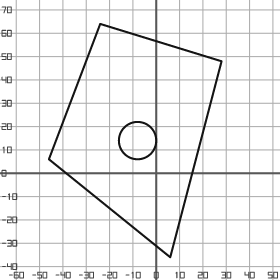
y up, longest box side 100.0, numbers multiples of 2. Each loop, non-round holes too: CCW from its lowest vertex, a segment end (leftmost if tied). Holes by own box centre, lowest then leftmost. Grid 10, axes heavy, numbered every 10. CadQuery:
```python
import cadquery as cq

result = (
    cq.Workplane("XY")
    .moveTo(6.0, -36.0)
    .lineTo(28.0, 48.0)
    .lineTo(-24.0, 64.0)
    .lineTo(-46.0, 6.0)
    .close()
    .moveTo(-8.0, 14.0)
    .circle(8.0)
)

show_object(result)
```